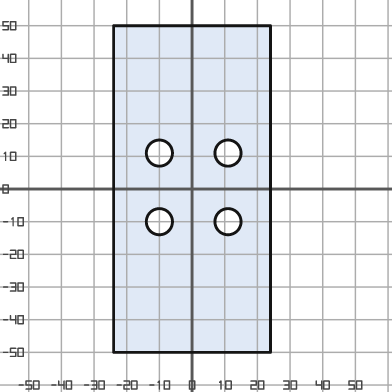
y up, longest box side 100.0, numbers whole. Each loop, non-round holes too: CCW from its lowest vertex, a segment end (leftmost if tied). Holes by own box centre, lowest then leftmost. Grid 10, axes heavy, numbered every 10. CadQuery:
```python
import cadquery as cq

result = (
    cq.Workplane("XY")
    .moveTo(-24.0, -50.0)
    .lineTo(24.0, -50.0)
    .lineTo(24.0, 50.0)
    .lineTo(-24.0, 50.0)
    .close()
    .moveTo(-10.0, -10.0)
    .circle(4.0)
    .moveTo(11.0, -10.0)
    .circle(4.0)
    .moveTo(-10.0, 11.0)
    .circle(4.0)
    .moveTo(11.0, 11.0)
    .circle(4.0)
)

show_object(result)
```